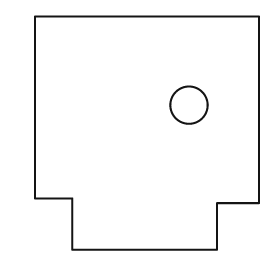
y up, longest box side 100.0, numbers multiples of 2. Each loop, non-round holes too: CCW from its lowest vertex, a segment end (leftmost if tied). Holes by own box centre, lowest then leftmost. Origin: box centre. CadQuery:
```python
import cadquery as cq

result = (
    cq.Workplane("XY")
    .moveTo(-32.0, -50.0)
    .lineTo(30.0, -50.0)
    .lineTo(30.0, -30.0)
    .lineTo(48.0, -30.0)
    .lineTo(48.0, 50.0)
    .lineTo(-48.0, 50.0)
    .lineTo(-48.0, -28.0)
    .lineTo(-32.0, -28.0)
    .close()
    .moveTo(18.0, 12.0)
    .circle(8.0)
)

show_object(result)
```